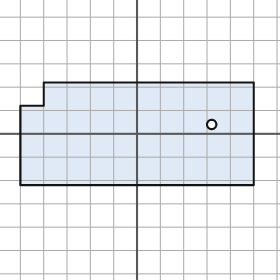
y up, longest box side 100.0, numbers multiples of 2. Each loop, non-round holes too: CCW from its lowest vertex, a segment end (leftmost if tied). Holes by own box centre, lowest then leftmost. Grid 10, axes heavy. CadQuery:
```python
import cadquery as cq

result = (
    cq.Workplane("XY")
    .moveTo(-50.0, -22.0)
    .lineTo(50.0, -22.0)
    .lineTo(50.0, 22.0)
    .lineTo(-40.0, 22.0)
    .lineTo(-40.0, 12.0)
    .lineTo(-50.0, 12.0)
    .close()
    .moveTo(32.0, 4.0)
    .circle(2.0)
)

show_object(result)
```